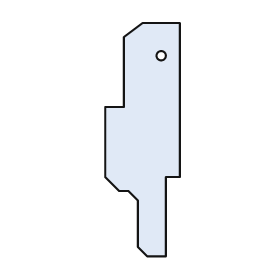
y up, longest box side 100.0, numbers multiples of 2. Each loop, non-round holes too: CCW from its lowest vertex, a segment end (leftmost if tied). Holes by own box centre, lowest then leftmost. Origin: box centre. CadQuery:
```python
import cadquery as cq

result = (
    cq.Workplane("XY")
    .moveTo(2.0, -50.0)
    .lineTo(10.0, -50.0)
    .lineTo(10.0, -16.0)
    .lineTo(16.0, -16.0)
    .lineTo(16.0, 50.0)
    .lineTo(0.0, 50.0)
    .lineTo(-8.0, 44.0)
    .lineTo(-8.0, 14.0)
    .lineTo(-16.0, 14.0)
    .lineTo(-16.0, -16.0)
    .lineTo(-10.0, -22.0)
    .lineTo(-6.0, -22.0)
    .lineTo(-2.0, -26.0)
    .lineTo(-2.0, -46.0)
    .close()
    .moveTo(8.0, 36.0)
    .circle(2.0)
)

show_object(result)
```